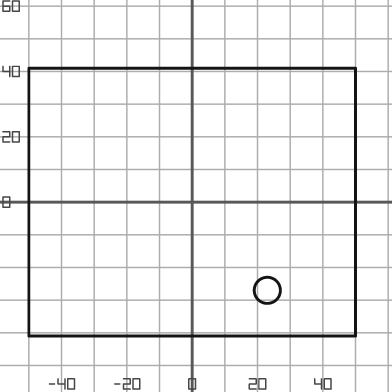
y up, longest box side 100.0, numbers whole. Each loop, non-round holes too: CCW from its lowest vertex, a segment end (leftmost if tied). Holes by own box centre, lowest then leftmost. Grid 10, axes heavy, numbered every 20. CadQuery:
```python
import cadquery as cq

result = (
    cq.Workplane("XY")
    .moveTo(-50.0, -41.0)
    .lineTo(50.0, -41.0)
    .lineTo(50.0, 41.0)
    .lineTo(-50.0, 41.0)
    .close()
    .moveTo(23.0, -27.0)
    .circle(4.0)
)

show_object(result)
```